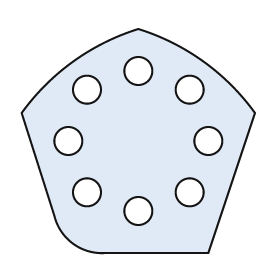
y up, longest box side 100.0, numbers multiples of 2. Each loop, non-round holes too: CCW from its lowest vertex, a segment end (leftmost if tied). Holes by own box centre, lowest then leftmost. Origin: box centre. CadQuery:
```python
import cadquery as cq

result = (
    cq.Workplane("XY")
    .moveTo(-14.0, -48.0)
    .lineTo(30.0, -48.0)
    .lineTo(50.0, 12.0)
    .threePointArc((28.0, 34.0), (0.0, 48.0))
    .threePointArc((-28.0, 34.0), (-50.0, 12.0))
    .lineTo(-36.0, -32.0)
    .threePointArc((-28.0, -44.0), (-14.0, -48.0))
    .close()
    .moveTo(0.0, -30.0)
    .circle(6.0)
    .moveTo(-22.0, -22.0)
    .circle(6.0)
    .moveTo(22.0, -22.0)
    .circle(6.0)
    .moveTo(-30.0, 0.0)
    .circle(6.0)
    .moveTo(30.0, 0.0)
    .circle(6.0)
    .moveTo(-22.0, 22.0)
    .circle(6.0)
    .moveTo(22.0, 22.0)
    .circle(6.0)
    .moveTo(0.0, 30.0)
    .circle(6.0)
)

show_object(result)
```